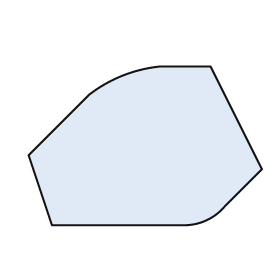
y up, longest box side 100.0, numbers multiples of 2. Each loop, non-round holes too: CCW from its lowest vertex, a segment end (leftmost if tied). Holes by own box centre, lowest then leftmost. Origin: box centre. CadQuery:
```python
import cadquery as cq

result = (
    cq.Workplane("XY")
    .moveTo(-40.0, -34.0)
    .lineTo(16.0, -34.0)
    .threePointArc((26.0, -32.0), (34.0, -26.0))
    .lineTo(50.0, -10.0)
    .lineTo(28.0, 34.0)
    .lineTo(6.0, 34.0)
    .threePointArc((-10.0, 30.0), (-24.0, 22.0))
    .lineTo(-50.0, -4.0)
    .close()
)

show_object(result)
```